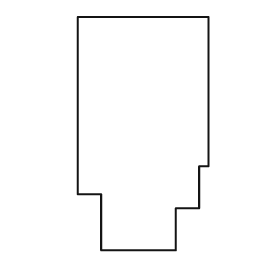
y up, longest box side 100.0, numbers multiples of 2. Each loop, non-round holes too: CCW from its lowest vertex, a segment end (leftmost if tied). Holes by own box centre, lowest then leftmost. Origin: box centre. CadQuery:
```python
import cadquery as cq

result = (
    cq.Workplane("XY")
    .moveTo(-18.0, -50.0)
    .lineTo(14.0, -50.0)
    .lineTo(14.0, -32.0)
    .lineTo(24.0, -32.0)
    .lineTo(24.0, -14.0)
    .lineTo(28.0, -14.0)
    .lineTo(28.0, 50.0)
    .lineTo(-28.0, 50.0)
    .lineTo(-28.0, -26.0)
    .lineTo(-18.0, -26.0)
    .close()
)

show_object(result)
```